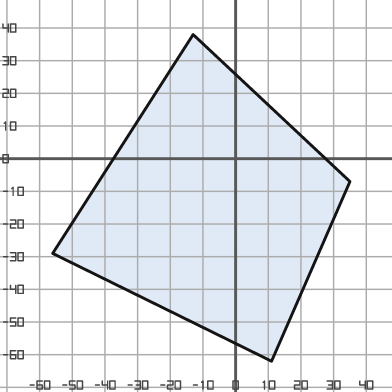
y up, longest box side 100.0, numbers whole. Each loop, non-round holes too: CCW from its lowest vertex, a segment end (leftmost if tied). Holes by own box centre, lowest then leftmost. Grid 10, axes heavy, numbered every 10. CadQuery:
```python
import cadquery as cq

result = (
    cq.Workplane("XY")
    .moveTo(11.0, -62.0)
    .lineTo(35.0, -7.0)
    .lineTo(-13.0, 38.0)
    .lineTo(-56.0, -29.0)
    .close()
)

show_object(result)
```